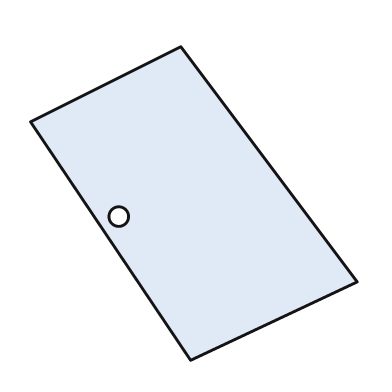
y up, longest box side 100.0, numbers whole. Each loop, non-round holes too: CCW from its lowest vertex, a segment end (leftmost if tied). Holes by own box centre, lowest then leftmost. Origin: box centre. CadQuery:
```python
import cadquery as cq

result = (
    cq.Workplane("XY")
    .moveTo(-1.0, -48.0)
    .lineTo(50.0, -24.0)
    .lineTo(-4.0, 48.0)
    .lineTo(-50.0, 25.0)
    .close()
    .moveTo(-23.0, -4.0)
    .circle(3.0)
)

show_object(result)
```